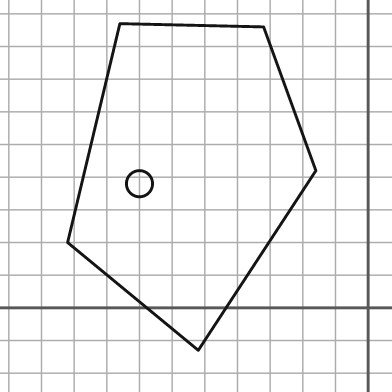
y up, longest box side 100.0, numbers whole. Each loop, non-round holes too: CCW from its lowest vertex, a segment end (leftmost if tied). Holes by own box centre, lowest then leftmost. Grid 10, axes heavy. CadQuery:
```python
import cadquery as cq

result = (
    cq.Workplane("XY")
    .moveTo(-52.0, -13.0)
    .lineTo(-16.0, 42.0)
    .lineTo(-32.0, 86.0)
    .lineTo(-76.0, 87.0)
    .lineTo(-92.0, 20.0)
    .close()
    .moveTo(-70.0, 38.0)
    .circle(4.0)
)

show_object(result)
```